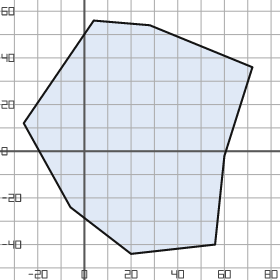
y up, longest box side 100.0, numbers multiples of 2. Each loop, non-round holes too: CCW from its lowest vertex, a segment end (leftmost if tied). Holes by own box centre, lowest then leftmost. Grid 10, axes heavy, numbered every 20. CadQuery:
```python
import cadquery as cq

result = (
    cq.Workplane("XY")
    .moveTo(20.0, -44.0)
    .lineTo(56.0, -40.0)
    .lineTo(60.0, -2.0)
    .lineTo(72.0, 36.0)
    .lineTo(28.0, 54.0)
    .lineTo(4.0, 56.0)
    .lineTo(-26.0, 12.0)
    .lineTo(-6.0, -24.0)
    .close()
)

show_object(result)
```